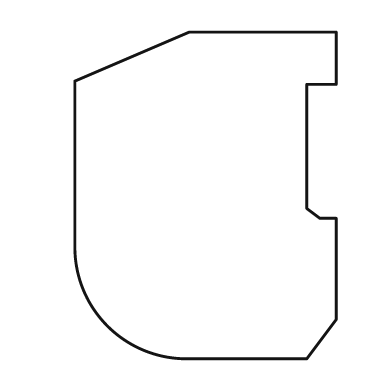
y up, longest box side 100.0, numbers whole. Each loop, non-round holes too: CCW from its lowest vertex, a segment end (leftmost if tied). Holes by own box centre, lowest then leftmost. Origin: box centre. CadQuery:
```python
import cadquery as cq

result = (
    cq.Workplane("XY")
    .moveTo(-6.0, -50.0)
    .lineTo(31.0, -50.0)
    .lineTo(40.0, -38.0)
    .lineTo(40.0, -7.0)
    .lineTo(35.0, -7.0)
    .lineTo(31.0, -4.0)
    .lineTo(31.0, 34.0)
    .lineTo(40.0, 34.0)
    .lineTo(40.0, 50.0)
    .lineTo(-5.0, 50.0)
    .lineTo(-40.0, 35.0)
    .lineTo(-40.0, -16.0)
    .threePointArc((-30.0, -40.0), (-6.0, -50.0))
    .close()
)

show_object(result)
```